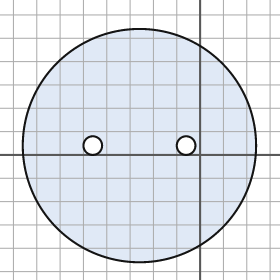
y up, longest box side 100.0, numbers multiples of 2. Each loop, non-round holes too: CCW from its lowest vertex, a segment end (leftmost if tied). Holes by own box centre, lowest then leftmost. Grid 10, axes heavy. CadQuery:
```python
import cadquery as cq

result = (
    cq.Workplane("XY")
    .moveTo(-26.0, 4.0)
    .circle(50.0)
    .moveTo(-46.0, 4.0)
    .circle(4.0)
    .moveTo(-6.0, 4.0)
    .circle(4.0)
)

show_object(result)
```